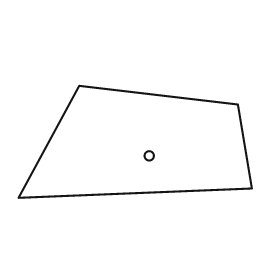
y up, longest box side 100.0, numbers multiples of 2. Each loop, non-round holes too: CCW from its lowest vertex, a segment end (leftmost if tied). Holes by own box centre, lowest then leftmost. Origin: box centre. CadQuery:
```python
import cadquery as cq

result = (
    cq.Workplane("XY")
    .moveTo(-50.0, -24.0)
    .lineTo(50.0, -20.0)
    .lineTo(44.0, 16.0)
    .lineTo(-24.0, 24.0)
    .close()
    .moveTo(6.0, -6.0)
    .circle(2.0)
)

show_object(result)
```